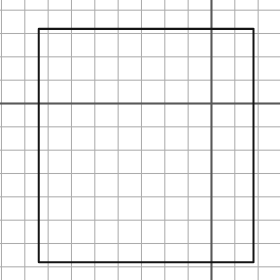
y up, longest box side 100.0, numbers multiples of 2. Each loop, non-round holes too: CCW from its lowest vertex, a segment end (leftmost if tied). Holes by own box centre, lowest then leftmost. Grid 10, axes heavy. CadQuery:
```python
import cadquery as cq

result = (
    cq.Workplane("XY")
    .moveTo(-74.0, -68.0)
    .lineTo(18.0, -68.0)
    .lineTo(18.0, 32.0)
    .lineTo(-74.0, 32.0)
    .close()
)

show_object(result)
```